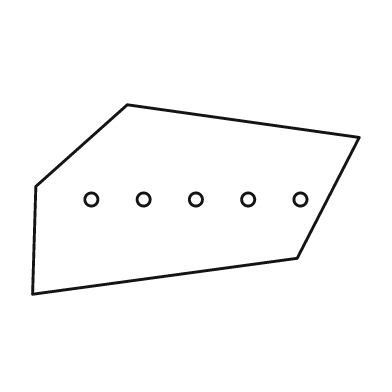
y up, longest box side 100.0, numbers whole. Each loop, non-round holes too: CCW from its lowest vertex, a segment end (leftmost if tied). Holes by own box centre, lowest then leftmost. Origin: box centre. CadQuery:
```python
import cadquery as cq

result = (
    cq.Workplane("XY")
    .moveTo(-50.0, -29.0)
    .lineTo(31.0, -18.0)
    .lineTo(50.0, 19.0)
    .lineTo(-21.0, 29.0)
    .lineTo(-49.0, 4.0)
    .close()
    .moveTo(-32.0, 0.0)
    .circle(2.0)
    .moveTo(-16.0, 0.0)
    .circle(2.0)
    .moveTo(0.0, 0.0)
    .circle(2.0)
    .moveTo(16.0, 0.0)
    .circle(2.0)
    .moveTo(32.0, 0.0)
    .circle(2.0)
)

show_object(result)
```